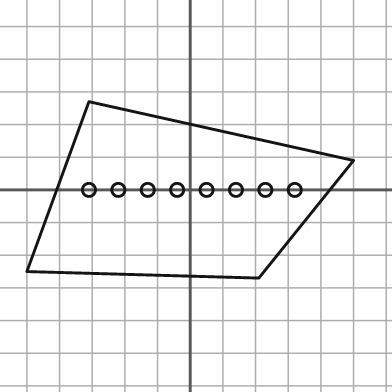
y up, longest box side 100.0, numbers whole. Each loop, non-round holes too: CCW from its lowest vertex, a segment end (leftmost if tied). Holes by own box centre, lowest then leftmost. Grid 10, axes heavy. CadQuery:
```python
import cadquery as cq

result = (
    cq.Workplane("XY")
    .moveTo(21.0, -27.0)
    .lineTo(50.0, 9.0)
    .lineTo(-31.0, 27.0)
    .lineTo(-50.0, -25.0)
    .close()
    .moveTo(-31.0, 0.0)
    .circle(2.0)
    .moveTo(-22.0, 0.0)
    .circle(2.0)
    .moveTo(-13.0, 0.0)
    .circle(2.0)
    .moveTo(-4.0, 0.0)
    .circle(2.0)
    .moveTo(5.0, 0.0)
    .circle(2.0)
    .moveTo(14.0, 0.0)
    .circle(2.0)
    .moveTo(23.0, 0.0)
    .circle(2.0)
    .moveTo(32.0, 0.0)
    .circle(2.0)
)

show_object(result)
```